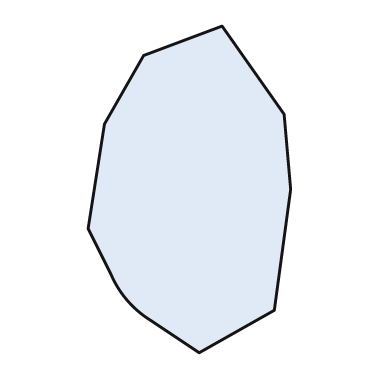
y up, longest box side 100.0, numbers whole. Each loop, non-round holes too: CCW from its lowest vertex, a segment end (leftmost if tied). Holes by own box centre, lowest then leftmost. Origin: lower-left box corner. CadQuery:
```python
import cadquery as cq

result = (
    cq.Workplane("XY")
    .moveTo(34.0, 0.0)
    .lineTo(57.0, 13.0)
    .lineTo(62.0, 50.0)
    .lineTo(60.0, 73.0)
    .lineTo(41.0, 100.0)
    .lineTo(17.0, 91.0)
    .lineTo(5.0, 70.0)
    .lineTo(0.0, 38.0)
    .lineTo(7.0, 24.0)
    .threePointArc((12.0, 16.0), (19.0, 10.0))
    .close()
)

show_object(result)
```